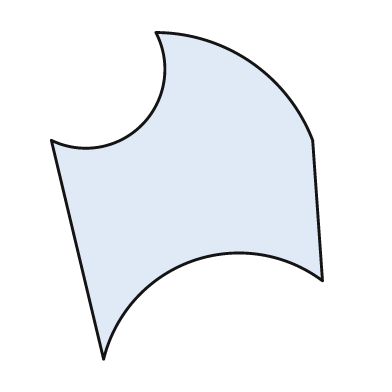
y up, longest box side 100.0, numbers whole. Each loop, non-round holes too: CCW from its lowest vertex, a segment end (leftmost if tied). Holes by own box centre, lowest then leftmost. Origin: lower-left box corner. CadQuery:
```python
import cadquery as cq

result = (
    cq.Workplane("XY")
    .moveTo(16.0, 0.0)
    .threePointArc((43.0, 30.0), (83.0, 24.0))
    .lineTo(80.0, 67.0)
    .threePointArc((61.0, 91.0), (32.0, 100.0))
    .threePointArc((28.0, 72.0), (0.0, 67.0))
    .close()
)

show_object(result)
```